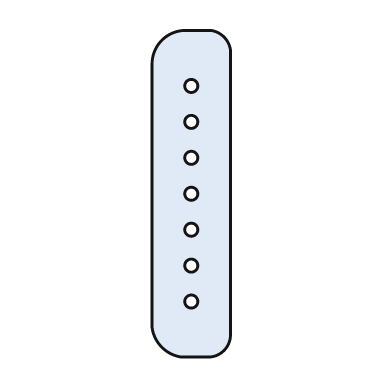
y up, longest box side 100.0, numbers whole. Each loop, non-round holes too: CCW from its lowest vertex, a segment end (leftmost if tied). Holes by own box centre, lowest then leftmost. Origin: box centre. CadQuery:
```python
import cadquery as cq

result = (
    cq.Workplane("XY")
    .moveTo(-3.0, -50.0)
    .lineTo(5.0, -50.0)
    .threePointArc((10.0, -48.0), (12.0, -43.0))
    .lineTo(12.0, 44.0)
    .threePointArc((10.0, 48.0), (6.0, 50.0))
    .lineTo(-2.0, 50.0)
    .threePointArc((-9.0, 47.0), (-12.0, 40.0))
    .lineTo(-12.0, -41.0)
    .threePointArc((-9.0, -47.0), (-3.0, -50.0))
    .close()
    .moveTo(0.0, -33.0)
    .circle(2.0)
    .moveTo(0.0, -22.0)
    .circle(2.0)
    .moveTo(0.0, -11.0)
    .circle(2.0)
    .moveTo(0.0, 0.0)
    .circle(2.0)
    .moveTo(0.0, 11.0)
    .circle(2.0)
    .moveTo(0.0, 22.0)
    .circle(2.0)
    .moveTo(0.0, 33.0)
    .circle(2.0)
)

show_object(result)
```